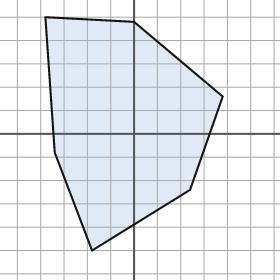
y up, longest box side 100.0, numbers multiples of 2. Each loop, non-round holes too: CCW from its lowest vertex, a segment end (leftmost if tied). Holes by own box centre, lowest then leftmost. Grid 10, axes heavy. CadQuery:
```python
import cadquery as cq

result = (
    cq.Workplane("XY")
    .moveTo(-18.0, -50.0)
    .lineTo(24.0, -24.0)
    .lineTo(38.0, 16.0)
    .lineTo(0.0, 48.0)
    .lineTo(-38.0, 50.0)
    .lineTo(-34.0, -8.0)
    .close()
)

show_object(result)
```